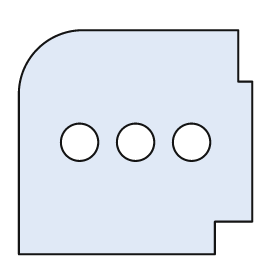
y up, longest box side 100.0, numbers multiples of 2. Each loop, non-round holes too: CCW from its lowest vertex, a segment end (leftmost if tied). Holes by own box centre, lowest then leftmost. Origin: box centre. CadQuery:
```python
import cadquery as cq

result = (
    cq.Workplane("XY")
    .moveTo(-50.0, -48.0)
    .lineTo(34.0, -48.0)
    .lineTo(34.0, -34.0)
    .lineTo(50.0, -34.0)
    .lineTo(50.0, 26.0)
    .lineTo(44.0, 26.0)
    .lineTo(44.0, 48.0)
    .lineTo(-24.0, 48.0)
    .threePointArc((-42.0, 40.0), (-50.0, 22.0))
    .close()
    .moveTo(-24.0, 0.0)
    .circle(8.0)
    .moveTo(0.0, 0.0)
    .circle(8.0)
    .moveTo(24.0, 0.0)
    .circle(8.0)
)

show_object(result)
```